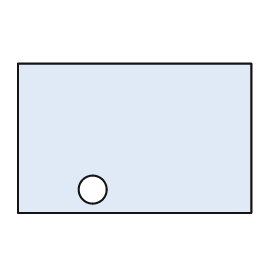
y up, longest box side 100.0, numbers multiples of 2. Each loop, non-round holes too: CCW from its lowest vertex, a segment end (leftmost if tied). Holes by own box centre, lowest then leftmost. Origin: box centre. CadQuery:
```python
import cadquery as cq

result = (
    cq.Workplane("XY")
    .moveTo(-50.0, -32.0)
    .lineTo(50.0, -32.0)
    .lineTo(50.0, 32.0)
    .lineTo(-50.0, 32.0)
    .close()
    .moveTo(-18.0, -22.0)
    .circle(6.0)
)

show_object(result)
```